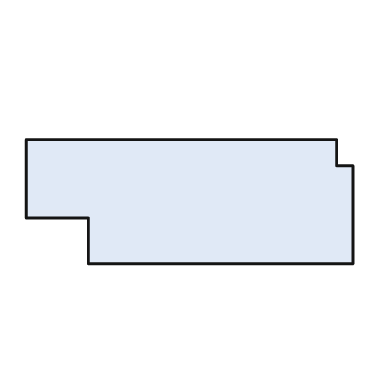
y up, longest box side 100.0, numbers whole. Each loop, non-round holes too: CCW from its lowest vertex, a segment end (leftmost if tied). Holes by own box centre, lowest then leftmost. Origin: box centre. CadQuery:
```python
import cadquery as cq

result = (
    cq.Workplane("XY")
    .moveTo(-31.0, -19.0)
    .lineTo(50.0, -19.0)
    .lineTo(50.0, 11.0)
    .lineTo(45.0, 11.0)
    .lineTo(45.0, 19.0)
    .lineTo(-50.0, 19.0)
    .lineTo(-50.0, -5.0)
    .lineTo(-31.0, -5.0)
    .close()
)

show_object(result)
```